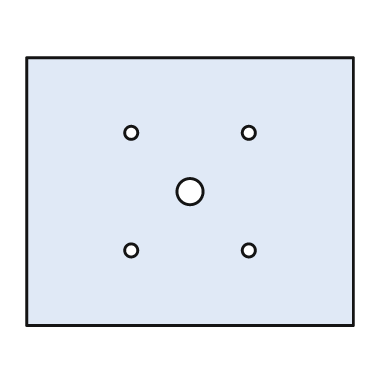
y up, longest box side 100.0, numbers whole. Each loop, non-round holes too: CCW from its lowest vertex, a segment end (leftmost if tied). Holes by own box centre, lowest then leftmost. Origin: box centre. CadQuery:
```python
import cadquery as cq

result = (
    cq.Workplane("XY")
    .moveTo(-50.0, -41.0)
    .lineTo(50.0, -41.0)
    .lineTo(50.0, 41.0)
    .lineTo(-50.0, 41.0)
    .close()
    .moveTo(-18.0, -18.0)
    .circle(2.0)
    .moveTo(18.0, -18.0)
    .circle(2.0)
    .moveTo(0.0, 0.0)
    .circle(4.0)
    .moveTo(-18.0, 18.0)
    .circle(2.0)
    .moveTo(18.0, 18.0)
    .circle(2.0)
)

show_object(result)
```